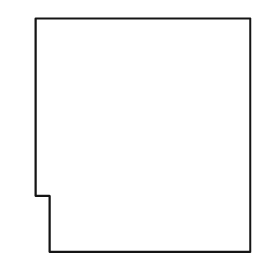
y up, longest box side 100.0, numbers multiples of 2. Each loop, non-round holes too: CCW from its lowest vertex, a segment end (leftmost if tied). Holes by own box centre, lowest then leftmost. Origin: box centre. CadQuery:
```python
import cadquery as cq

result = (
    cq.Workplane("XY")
    .moveTo(-40.0, -50.0)
    .lineTo(46.0, -50.0)
    .lineTo(46.0, 50.0)
    .lineTo(-46.0, 50.0)
    .lineTo(-46.0, -26.0)
    .lineTo(-40.0, -26.0)
    .close()
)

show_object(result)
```